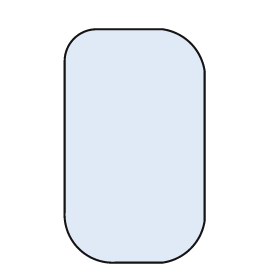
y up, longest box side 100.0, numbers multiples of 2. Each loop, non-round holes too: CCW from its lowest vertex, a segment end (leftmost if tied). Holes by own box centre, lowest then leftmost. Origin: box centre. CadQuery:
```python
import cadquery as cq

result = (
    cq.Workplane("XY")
    .moveTo(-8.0, -50.0)
    .lineTo(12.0, -50.0)
    .threePointArc((24.0, -44.0), (30.0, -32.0))
    .lineTo(30.0, 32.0)
    .threePointArc((24.0, 44.0), (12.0, 50.0))
    .lineTo(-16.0, 50.0)
    .threePointArc((-26.0, 46.0), (-30.0, 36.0))
    .lineTo(-30.0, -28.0)
    .threePointArc((-24.0, -44.0), (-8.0, -50.0))
    .close()
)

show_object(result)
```